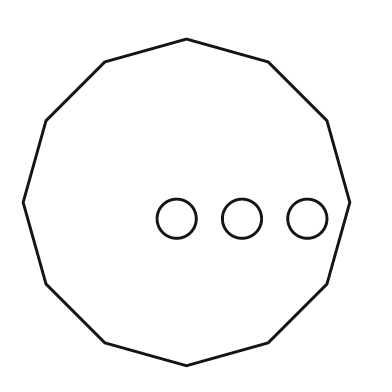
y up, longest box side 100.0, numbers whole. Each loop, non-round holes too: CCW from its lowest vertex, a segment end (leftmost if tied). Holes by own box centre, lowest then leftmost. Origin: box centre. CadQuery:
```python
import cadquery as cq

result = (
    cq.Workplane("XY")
    .moveTo(0.0, -50.0)
    .lineTo(25.0, -43.0)
    .lineTo(43.0, -25.0)
    .lineTo(50.0, 0.0)
    .lineTo(43.0, 25.0)
    .lineTo(25.0, 43.0)
    .lineTo(0.0, 50.0)
    .lineTo(-25.0, 43.0)
    .lineTo(-43.0, 25.0)
    .lineTo(-50.0, 0.0)
    .lineTo(-43.0, -25.0)
    .lineTo(-25.0, -43.0)
    .close()
    .moveTo(-3.0, -5.0)
    .circle(6.0)
    .moveTo(17.0, -5.0)
    .circle(6.0)
    .moveTo(37.0, -5.0)
    .circle(6.0)
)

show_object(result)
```